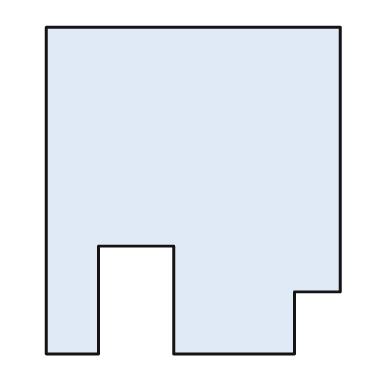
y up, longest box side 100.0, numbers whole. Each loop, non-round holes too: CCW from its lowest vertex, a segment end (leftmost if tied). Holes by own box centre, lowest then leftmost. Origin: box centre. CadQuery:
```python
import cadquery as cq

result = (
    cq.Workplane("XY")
    .moveTo(-45.0, -50.0)
    .lineTo(-29.0, -50.0)
    .lineTo(-29.0, -17.0)
    .lineTo(-6.0, -17.0)
    .lineTo(-6.0, -50.0)
    .lineTo(31.0, -50.0)
    .lineTo(31.0, -31.0)
    .lineTo(45.0, -31.0)
    .lineTo(45.0, 50.0)
    .lineTo(-45.0, 50.0)
    .close()
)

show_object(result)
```